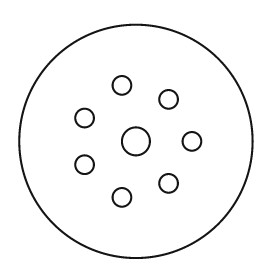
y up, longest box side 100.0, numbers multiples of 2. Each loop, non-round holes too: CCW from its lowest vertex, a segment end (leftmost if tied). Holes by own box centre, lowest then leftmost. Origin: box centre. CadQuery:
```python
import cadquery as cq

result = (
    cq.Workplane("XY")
    .moveTo(0.0, 0.0)
    .circle(50.0)
    .moveTo(-6.0, -24.0)
    .circle(4.0)
    .moveTo(14.0, -18.0)
    .circle(4.0)
    .moveTo(-22.0, -10.0)
    .circle(4.0)
    .moveTo(0.0, 0.0)
    .circle(6.0)
    .moveTo(24.0, 0.0)
    .circle(4.0)
    .moveTo(-22.0, 10.0)
    .circle(4.0)
    .moveTo(14.0, 18.0)
    .circle(4.0)
    .moveTo(-6.0, 24.0)
    .circle(4.0)
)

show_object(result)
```